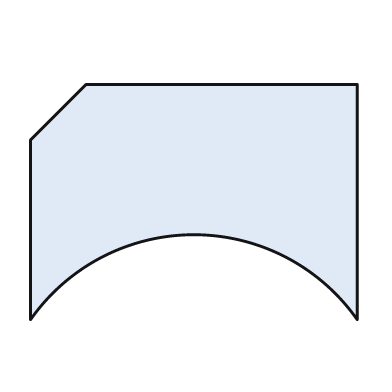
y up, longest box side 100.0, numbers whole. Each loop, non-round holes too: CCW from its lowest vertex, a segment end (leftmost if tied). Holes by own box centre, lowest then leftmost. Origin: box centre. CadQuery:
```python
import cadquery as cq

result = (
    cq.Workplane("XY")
    .moveTo(-50.0, -36.0)
    .threePointArc((0.0, -10.0), (50.0, -36.0))
    .lineTo(50.0, 36.0)
    .lineTo(-33.0, 36.0)
    .lineTo(-50.0, 19.0)
    .close()
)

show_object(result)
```